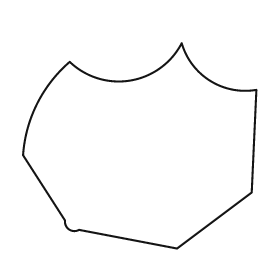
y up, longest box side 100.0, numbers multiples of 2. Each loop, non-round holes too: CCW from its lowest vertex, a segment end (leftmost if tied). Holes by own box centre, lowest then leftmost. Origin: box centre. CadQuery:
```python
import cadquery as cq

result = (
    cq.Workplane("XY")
    .moveTo(16.0, -44.0)
    .lineTo(48.0, -20.0)
    .lineTo(50.0, 24.0)
    .threePointArc((30.0, 28.0), (18.0, 44.0))
    .threePointArc((-4.0, 28.0), (-30.0, 36.0))
    .threePointArc((-44.0, 18.0), (-50.0, -4.0))
    .lineTo(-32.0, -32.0)
    .threePointArc((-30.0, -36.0), (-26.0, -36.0))
    .close()
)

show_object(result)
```